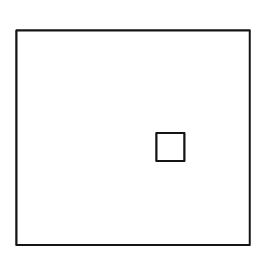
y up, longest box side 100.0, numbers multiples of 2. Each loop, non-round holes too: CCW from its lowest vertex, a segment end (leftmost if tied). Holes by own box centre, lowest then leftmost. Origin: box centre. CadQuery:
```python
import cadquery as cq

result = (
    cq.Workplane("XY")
    .moveTo(-50.0, -46.0)
    .lineTo(50.0, -46.0)
    .lineTo(50.0, 46.0)
    .lineTo(-50.0, 46.0)
    .close()
    .moveTo(10.0, -10.0)
    .lineTo(22.0, -10.0)
    .lineTo(22.0, 2.0)
    .lineTo(10.0, 2.0)
    .close()
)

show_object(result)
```